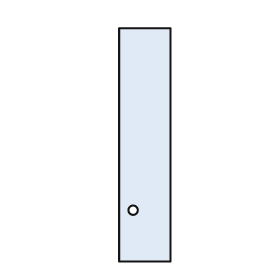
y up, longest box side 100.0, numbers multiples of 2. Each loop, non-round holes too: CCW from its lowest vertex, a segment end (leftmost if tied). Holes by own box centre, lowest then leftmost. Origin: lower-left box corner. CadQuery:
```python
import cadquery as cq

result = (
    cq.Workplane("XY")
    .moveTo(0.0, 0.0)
    .lineTo(22.0, 0.0)
    .lineTo(22.0, 100.0)
    .lineTo(0.0, 100.0)
    .close()
    .moveTo(6.0, 22.0)
    .circle(2.0)
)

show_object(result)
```